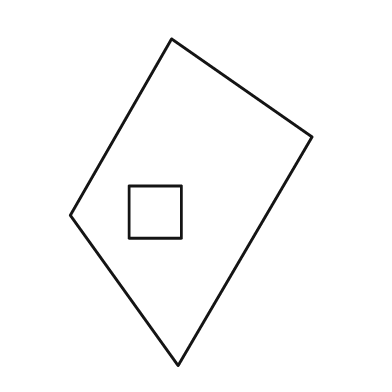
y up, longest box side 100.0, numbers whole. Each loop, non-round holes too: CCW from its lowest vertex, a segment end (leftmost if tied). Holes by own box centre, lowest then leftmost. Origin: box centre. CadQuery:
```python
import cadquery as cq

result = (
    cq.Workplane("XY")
    .moveTo(-4.0, -50.0)
    .lineTo(37.0, 20.0)
    .lineTo(-6.0, 50.0)
    .lineTo(-37.0, -4.0)
    .close()
    .moveTo(-19.0, -11.0)
    .lineTo(-3.0, -11.0)
    .lineTo(-3.0, 5.0)
    .lineTo(-19.0, 5.0)
    .close()
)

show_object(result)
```